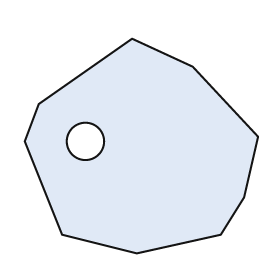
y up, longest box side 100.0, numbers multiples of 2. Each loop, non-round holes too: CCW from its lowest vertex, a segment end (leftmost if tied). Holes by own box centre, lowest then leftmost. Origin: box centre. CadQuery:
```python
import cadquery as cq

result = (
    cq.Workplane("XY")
    .moveTo(-2.0, -46.0)
    .lineTo(34.0, -38.0)
    .lineTo(44.0, -22.0)
    .lineTo(50.0, 4.0)
    .lineTo(22.0, 34.0)
    .lineTo(-4.0, 46.0)
    .lineTo(-44.0, 18.0)
    .lineTo(-50.0, 2.0)
    .lineTo(-34.0, -38.0)
    .close()
    .moveTo(-24.0, 2.0)
    .circle(8.0)
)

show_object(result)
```